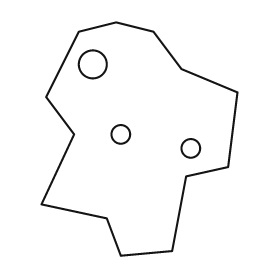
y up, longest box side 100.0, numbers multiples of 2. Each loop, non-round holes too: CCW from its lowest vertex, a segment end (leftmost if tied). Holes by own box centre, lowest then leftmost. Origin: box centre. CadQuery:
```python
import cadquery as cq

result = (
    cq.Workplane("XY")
    .moveTo(-8.0, -50.0)
    .lineTo(14.0, -48.0)
    .lineTo(20.0, -16.0)
    .lineTo(38.0, -12.0)
    .lineTo(42.0, 20.0)
    .lineTo(18.0, 30.0)
    .lineTo(6.0, 46.0)
    .lineTo(-10.0, 50.0)
    .lineTo(-26.0, 46.0)
    .lineTo(-40.0, 18.0)
    .lineTo(-28.0, 2.0)
    .lineTo(-42.0, -28.0)
    .lineTo(-14.0, -34.0)
    .close()
    .moveTo(22.0, -4.0)
    .circle(4.0)
    .moveTo(-8.0, 2.0)
    .circle(4.0)
    .moveTo(-20.0, 32.0)
    .circle(6.0)
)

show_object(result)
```